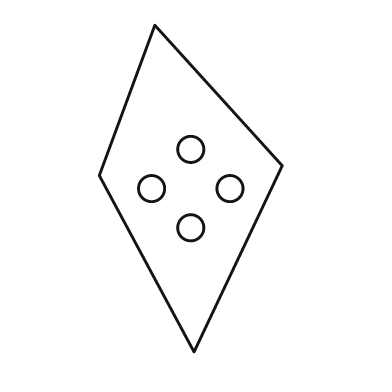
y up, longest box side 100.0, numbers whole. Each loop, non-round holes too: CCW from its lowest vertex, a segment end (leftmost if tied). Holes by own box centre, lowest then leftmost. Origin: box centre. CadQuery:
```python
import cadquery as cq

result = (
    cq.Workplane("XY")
    .moveTo(1.0, -50.0)
    .lineTo(28.0, 7.0)
    .lineTo(-11.0, 50.0)
    .lineTo(-28.0, 4.0)
    .close()
    .moveTo(0.0, -12.0)
    .circle(4.0)
    .moveTo(-12.0, 0.0)
    .circle(4.0)
    .moveTo(12.0, 0.0)
    .circle(4.0)
    .moveTo(0.0, 12.0)
    .circle(4.0)
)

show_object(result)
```